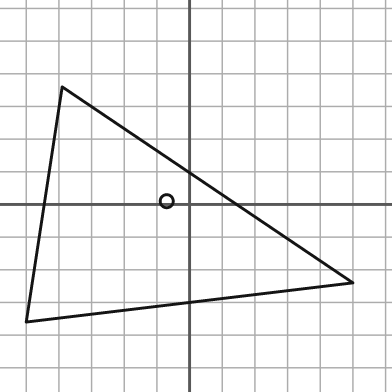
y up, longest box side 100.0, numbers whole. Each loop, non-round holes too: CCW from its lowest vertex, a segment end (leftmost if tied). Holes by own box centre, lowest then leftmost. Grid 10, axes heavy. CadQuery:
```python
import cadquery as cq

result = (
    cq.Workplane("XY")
    .moveTo(-50.0, -36.0)
    .lineTo(50.0, -24.0)
    .lineTo(-39.0, 36.0)
    .close()
    .moveTo(-7.0, 1.0)
    .circle(2.0)
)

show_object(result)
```